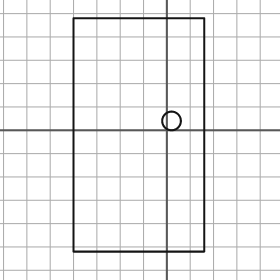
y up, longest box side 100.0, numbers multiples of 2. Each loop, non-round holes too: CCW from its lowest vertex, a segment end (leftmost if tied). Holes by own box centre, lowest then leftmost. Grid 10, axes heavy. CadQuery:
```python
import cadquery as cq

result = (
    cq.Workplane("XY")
    .moveTo(-40.0, -52.0)
    .lineTo(16.0, -52.0)
    .lineTo(16.0, 48.0)
    .lineTo(-40.0, 48.0)
    .close()
    .moveTo(2.0, 4.0)
    .circle(4.0)
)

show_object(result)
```